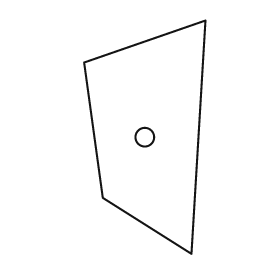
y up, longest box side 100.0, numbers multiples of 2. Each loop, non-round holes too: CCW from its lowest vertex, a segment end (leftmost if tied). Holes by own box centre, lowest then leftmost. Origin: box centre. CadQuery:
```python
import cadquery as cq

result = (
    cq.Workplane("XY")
    .moveTo(20.0, -50.0)
    .lineTo(26.0, 50.0)
    .lineTo(-26.0, 32.0)
    .lineTo(-18.0, -26.0)
    .close()
    .moveTo(0.0, 0.0)
    .circle(4.0)
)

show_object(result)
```